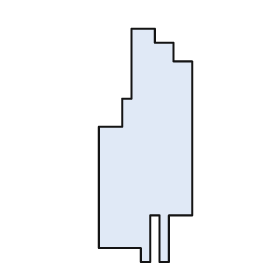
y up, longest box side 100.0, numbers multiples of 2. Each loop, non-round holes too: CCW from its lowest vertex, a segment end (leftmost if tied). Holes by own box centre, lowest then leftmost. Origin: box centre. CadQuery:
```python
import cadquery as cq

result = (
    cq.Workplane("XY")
    .moveTo(-2.0, -50.0)
    .lineTo(2.0, -50.0)
    .lineTo(2.0, -30.0)
    .lineTo(6.0, -30.0)
    .lineTo(6.0, -50.0)
    .lineTo(10.0, -50.0)
    .lineTo(10.0, -30.0)
    .lineTo(20.0, -30.0)
    .lineTo(20.0, 36.0)
    .lineTo(12.0, 36.0)
    .lineTo(12.0, 44.0)
    .lineTo(4.0, 44.0)
    .lineTo(4.0, 50.0)
    .lineTo(-6.0, 50.0)
    .lineTo(-6.0, 20.0)
    .lineTo(-10.0, 20.0)
    .lineTo(-10.0, 8.0)
    .lineTo(-20.0, 8.0)
    .lineTo(-20.0, -44.0)
    .lineTo(-2.0, -44.0)
    .close()
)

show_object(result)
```